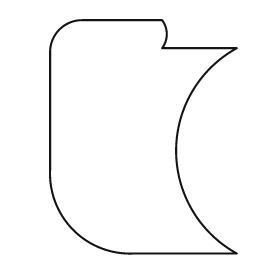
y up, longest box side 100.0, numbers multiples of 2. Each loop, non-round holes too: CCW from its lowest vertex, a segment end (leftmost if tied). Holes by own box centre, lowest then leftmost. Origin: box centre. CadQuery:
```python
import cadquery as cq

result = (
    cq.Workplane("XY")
    .moveTo(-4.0, -50.0)
    .lineTo(40.0, -50.0)
    .threePointArc((14.0, -6.0), (40.0, 38.0))
    .lineTo(8.0, 38.0)
    .threePointArc((10.0, 44.0), (8.0, 50.0))
    .lineTo(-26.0, 50.0)
    .threePointArc((-36.0, 46.0), (-40.0, 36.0))
    .lineTo(-40.0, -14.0)
    .threePointArc((-30.0, -40.0), (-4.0, -50.0))
    .close()
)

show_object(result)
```